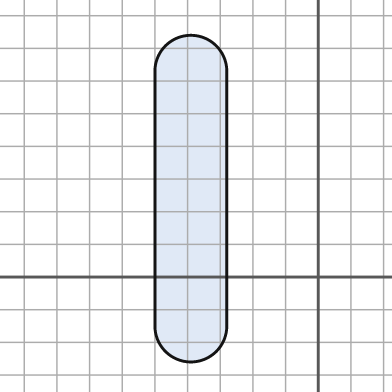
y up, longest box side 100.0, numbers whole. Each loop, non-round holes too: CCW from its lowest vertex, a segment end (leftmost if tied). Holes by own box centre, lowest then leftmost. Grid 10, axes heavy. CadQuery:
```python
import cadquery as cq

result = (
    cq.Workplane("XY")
    .moveTo(-50.0, -15.0)
    .threePointArc((-39.0, -26.0), (-28.0, -15.0))
    .lineTo(-28.0, 63.0)
    .threePointArc((-39.0, 74.0), (-50.0, 63.0))
    .close()
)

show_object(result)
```